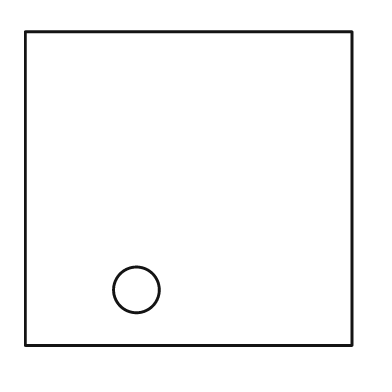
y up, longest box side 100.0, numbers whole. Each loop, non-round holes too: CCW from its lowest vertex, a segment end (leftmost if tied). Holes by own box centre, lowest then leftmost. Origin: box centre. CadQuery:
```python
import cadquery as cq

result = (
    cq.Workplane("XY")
    .moveTo(-50.0, -48.0)
    .lineTo(50.0, -48.0)
    .lineTo(50.0, 48.0)
    .lineTo(-50.0, 48.0)
    .close()
    .moveTo(-16.0, -31.0)
    .circle(7.0)
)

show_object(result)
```